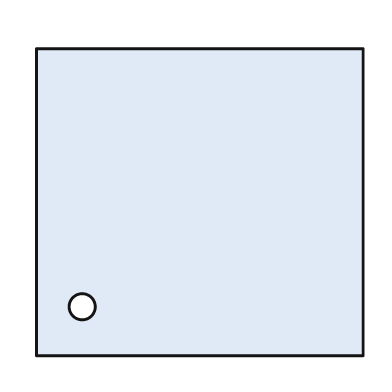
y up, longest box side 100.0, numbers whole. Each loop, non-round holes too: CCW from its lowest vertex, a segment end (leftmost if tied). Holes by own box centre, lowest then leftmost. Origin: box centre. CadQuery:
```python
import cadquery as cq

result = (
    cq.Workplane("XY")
    .moveTo(-50.0, -47.0)
    .lineTo(50.0, -47.0)
    .lineTo(50.0, 47.0)
    .lineTo(-50.0, 47.0)
    .close()
    .moveTo(-36.0, -32.0)
    .circle(4.0)
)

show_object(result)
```